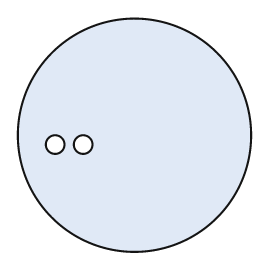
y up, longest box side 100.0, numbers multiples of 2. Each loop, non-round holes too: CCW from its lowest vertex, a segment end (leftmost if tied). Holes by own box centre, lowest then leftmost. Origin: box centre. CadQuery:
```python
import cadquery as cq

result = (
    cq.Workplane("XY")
    .moveTo(0.0, 0.0)
    .circle(50.0)
    .moveTo(-34.0, -4.0)
    .circle(4.0)
    .moveTo(-22.0, -4.0)
    .circle(4.0)
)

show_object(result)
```